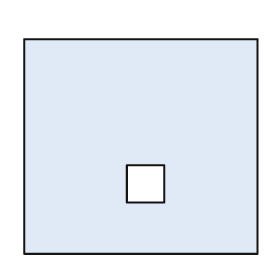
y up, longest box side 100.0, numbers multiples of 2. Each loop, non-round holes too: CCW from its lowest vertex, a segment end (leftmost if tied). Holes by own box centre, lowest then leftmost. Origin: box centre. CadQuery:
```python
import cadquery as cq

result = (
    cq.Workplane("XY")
    .moveTo(-50.0, -46.0)
    .lineTo(50.0, -46.0)
    .lineTo(50.0, 46.0)
    .lineTo(-50.0, 46.0)
    .close()
    .moveTo(-6.0, -24.0)
    .lineTo(10.0, -24.0)
    .lineTo(10.0, -8.0)
    .lineTo(-6.0, -8.0)
    .close()
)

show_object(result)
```